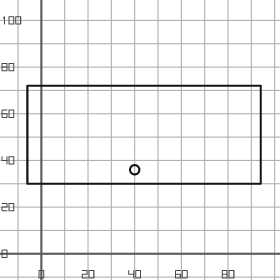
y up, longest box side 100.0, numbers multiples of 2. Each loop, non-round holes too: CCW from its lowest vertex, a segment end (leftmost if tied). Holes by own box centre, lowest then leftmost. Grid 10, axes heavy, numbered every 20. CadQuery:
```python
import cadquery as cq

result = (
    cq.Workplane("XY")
    .moveTo(-6.0, 30.0)
    .lineTo(94.0, 30.0)
    .lineTo(94.0, 72.0)
    .lineTo(-6.0, 72.0)
    .close()
    .moveTo(40.0, 36.0)
    .circle(2.0)
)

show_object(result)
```